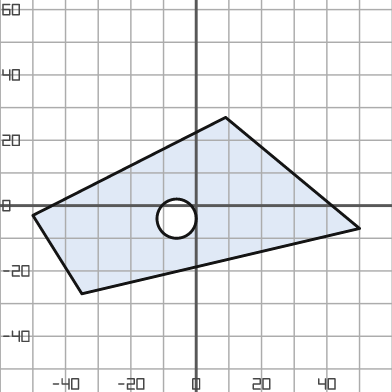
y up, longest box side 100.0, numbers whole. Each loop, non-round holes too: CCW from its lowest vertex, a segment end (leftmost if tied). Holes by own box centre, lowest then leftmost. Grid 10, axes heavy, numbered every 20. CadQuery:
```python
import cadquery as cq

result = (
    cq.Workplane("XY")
    .moveTo(-35.0, -27.0)
    .lineTo(50.0, -7.0)
    .lineTo(9.0, 27.0)
    .lineTo(-50.0, -3.0)
    .close()
    .moveTo(-6.0, -4.0)
    .circle(6.0)
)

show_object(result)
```